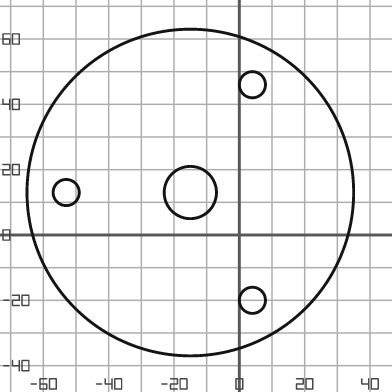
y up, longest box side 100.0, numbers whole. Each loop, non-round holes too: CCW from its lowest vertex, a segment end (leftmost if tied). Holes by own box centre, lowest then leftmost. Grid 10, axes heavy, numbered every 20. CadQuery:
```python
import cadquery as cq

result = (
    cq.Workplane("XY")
    .moveTo(-15.0, 13.0)
    .circle(50.0)
    .moveTo(4.0, -20.0)
    .circle(4.0)
    .moveTo(-53.0, 13.0)
    .circle(4.0)
    .moveTo(-15.0, 13.0)
    .circle(8.0)
    .moveTo(4.0, 46.0)
    .circle(4.0)
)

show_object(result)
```